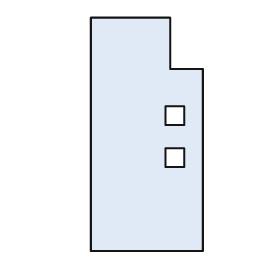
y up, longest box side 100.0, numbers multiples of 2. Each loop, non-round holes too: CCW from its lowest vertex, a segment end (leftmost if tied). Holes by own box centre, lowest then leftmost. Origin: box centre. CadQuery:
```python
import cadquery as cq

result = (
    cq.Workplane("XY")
    .moveTo(-24.0, -50.0)
    .lineTo(24.0, -50.0)
    .lineTo(24.0, 28.0)
    .lineTo(10.0, 28.0)
    .lineTo(10.0, 50.0)
    .lineTo(-24.0, 50.0)
    .close()
    .moveTo(8.0, -14.0)
    .lineTo(16.0, -14.0)
    .lineTo(16.0, -6.0)
    .lineTo(8.0, -6.0)
    .close()
    .moveTo(8.0, 4.0)
    .lineTo(16.0, 4.0)
    .lineTo(16.0, 12.0)
    .lineTo(8.0, 12.0)
    .close()
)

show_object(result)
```